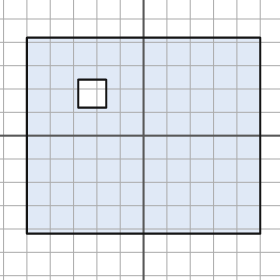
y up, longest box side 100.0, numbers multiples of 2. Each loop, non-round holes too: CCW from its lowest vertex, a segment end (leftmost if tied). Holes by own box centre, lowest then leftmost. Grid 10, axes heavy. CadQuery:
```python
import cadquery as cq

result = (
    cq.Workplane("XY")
    .moveTo(-50.0, -42.0)
    .lineTo(50.0, -42.0)
    .lineTo(50.0, 42.0)
    .lineTo(-50.0, 42.0)
    .close()
    .moveTo(-28.0, 12.0)
    .lineTo(-16.0, 12.0)
    .lineTo(-16.0, 24.0)
    .lineTo(-28.0, 24.0)
    .close()
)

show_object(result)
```